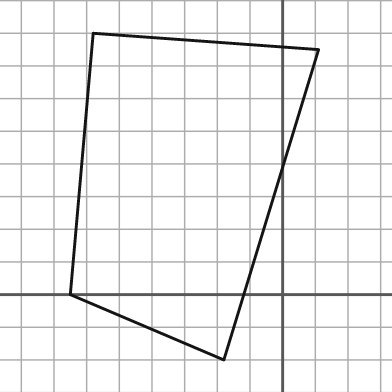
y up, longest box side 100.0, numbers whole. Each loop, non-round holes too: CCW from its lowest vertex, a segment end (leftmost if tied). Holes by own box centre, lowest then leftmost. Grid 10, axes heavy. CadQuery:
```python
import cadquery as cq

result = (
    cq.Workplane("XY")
    .moveTo(-18.0, -20.0)
    .lineTo(11.0, 75.0)
    .lineTo(-58.0, 80.0)
    .lineTo(-65.0, 0.0)
    .close()
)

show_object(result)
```